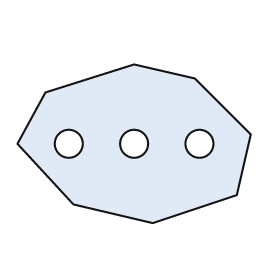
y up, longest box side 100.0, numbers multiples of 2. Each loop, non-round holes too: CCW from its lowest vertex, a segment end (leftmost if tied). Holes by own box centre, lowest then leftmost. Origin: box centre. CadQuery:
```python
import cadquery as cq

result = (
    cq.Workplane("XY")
    .moveTo(8.0, -34.0)
    .lineTo(44.0, -22.0)
    .lineTo(50.0, 4.0)
    .lineTo(26.0, 28.0)
    .lineTo(0.0, 34.0)
    .lineTo(-38.0, 22.0)
    .lineTo(-50.0, 0.0)
    .lineTo(-26.0, -26.0)
    .close()
    .moveTo(-28.0, 0.0)
    .circle(6.0)
    .moveTo(0.0, 0.0)
    .circle(6.0)
    .moveTo(28.0, 0.0)
    .circle(6.0)
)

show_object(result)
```